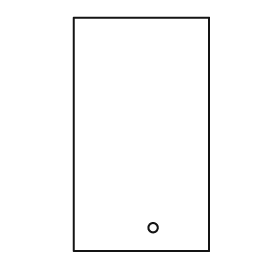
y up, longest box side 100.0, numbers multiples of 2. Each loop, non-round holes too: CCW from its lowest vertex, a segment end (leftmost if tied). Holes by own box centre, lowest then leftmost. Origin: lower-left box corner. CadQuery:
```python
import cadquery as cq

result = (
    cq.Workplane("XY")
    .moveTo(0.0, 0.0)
    .lineTo(58.0, 0.0)
    .lineTo(58.0, 100.0)
    .lineTo(0.0, 100.0)
    .close()
    .moveTo(34.0, 10.0)
    .circle(2.0)
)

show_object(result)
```